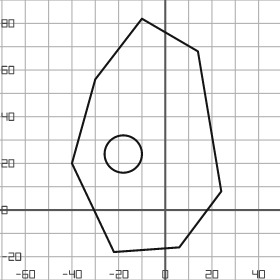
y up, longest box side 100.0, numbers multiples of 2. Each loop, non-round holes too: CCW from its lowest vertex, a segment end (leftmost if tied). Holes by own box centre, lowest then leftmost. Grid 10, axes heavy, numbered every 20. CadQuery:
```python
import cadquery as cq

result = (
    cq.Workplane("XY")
    .moveTo(-22.0, -18.0)
    .lineTo(6.0, -16.0)
    .lineTo(24.0, 8.0)
    .lineTo(14.0, 68.0)
    .lineTo(-10.0, 82.0)
    .lineTo(-30.0, 56.0)
    .lineTo(-40.0, 20.0)
    .close()
    .moveTo(-18.0, 24.0)
    .circle(8.0)
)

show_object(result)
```